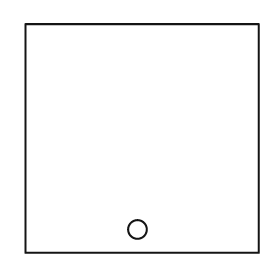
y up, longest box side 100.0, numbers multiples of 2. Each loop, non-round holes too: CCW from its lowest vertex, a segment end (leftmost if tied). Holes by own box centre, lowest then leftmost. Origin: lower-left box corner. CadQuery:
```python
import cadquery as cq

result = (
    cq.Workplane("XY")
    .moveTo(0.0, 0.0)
    .lineTo(100.0, 0.0)
    .lineTo(100.0, 98.0)
    .lineTo(0.0, 98.0)
    .close()
    .moveTo(48.0, 10.0)
    .circle(4.0)
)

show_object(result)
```